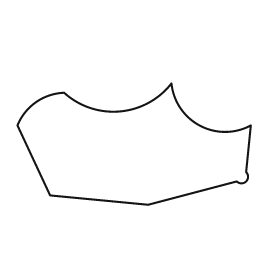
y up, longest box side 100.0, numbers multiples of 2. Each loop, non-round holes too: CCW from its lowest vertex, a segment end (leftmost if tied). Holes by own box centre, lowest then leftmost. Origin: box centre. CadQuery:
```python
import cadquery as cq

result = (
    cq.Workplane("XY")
    .moveTo(6.0, -26.0)
    .lineTo(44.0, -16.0)
    .threePointArc((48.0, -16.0), (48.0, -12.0))
    .lineTo(50.0, 8.0)
    .threePointArc((28.0, 8.0), (16.0, 26.0))
    .threePointArc((-6.0, 14.0), (-30.0, 22.0))
    .threePointArc((-42.0, 18.0), (-50.0, 8.0))
    .lineTo(-36.0, -22.0)
    .close()
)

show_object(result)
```